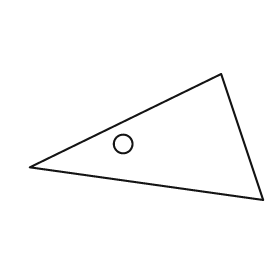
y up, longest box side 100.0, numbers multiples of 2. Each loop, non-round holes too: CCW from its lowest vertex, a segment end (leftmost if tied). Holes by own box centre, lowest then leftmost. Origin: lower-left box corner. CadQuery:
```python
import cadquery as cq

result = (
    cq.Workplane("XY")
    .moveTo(100.0, 0.0)
    .lineTo(82.0, 54.0)
    .lineTo(0.0, 14.0)
    .close()
    .moveTo(40.0, 24.0)
    .circle(4.0)
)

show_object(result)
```